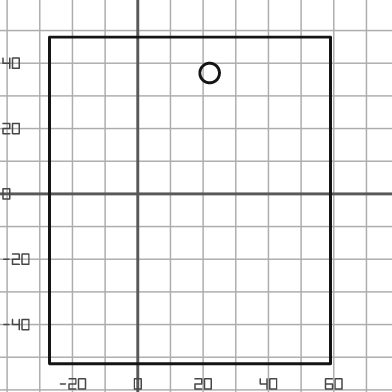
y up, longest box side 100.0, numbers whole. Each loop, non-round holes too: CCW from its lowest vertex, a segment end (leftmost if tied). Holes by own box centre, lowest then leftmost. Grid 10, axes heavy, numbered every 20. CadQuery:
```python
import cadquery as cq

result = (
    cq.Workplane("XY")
    .moveTo(-27.0, -52.0)
    .lineTo(59.0, -52.0)
    .lineTo(59.0, 48.0)
    .lineTo(-27.0, 48.0)
    .close()
    .moveTo(22.0, 37.0)
    .circle(3.0)
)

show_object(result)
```